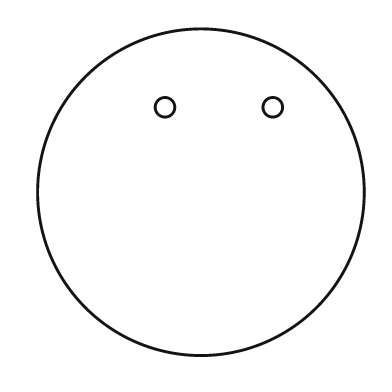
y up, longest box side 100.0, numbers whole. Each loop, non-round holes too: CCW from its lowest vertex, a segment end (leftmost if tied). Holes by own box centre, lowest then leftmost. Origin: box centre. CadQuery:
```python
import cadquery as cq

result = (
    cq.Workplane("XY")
    .moveTo(0.0, 0.0)
    .circle(50.0)
    .moveTo(-11.0, 26.0)
    .circle(3.0)
    .moveTo(22.0, 26.0)
    .circle(3.0)
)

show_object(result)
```